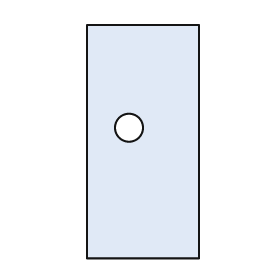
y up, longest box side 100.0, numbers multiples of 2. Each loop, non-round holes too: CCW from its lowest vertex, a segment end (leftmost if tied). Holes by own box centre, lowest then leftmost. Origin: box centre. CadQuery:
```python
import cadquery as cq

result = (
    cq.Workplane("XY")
    .moveTo(-24.0, -50.0)
    .lineTo(24.0, -50.0)
    .lineTo(24.0, 50.0)
    .lineTo(-24.0, 50.0)
    .close()
    .moveTo(-6.0, 6.0)
    .circle(6.0)
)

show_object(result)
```